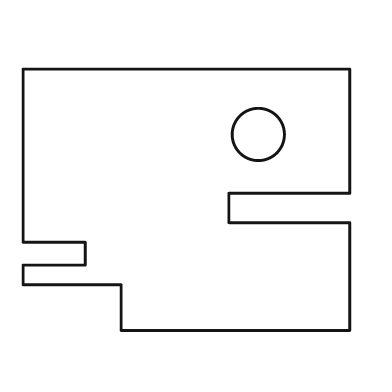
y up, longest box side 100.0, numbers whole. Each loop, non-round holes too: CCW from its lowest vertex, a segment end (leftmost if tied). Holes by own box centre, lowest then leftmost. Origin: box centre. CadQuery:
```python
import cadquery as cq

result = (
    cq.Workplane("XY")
    .moveTo(-20.0, -40.0)
    .lineTo(50.0, -40.0)
    .lineTo(50.0, -7.0)
    .lineTo(13.0, -7.0)
    .lineTo(13.0, 2.0)
    .lineTo(50.0, 2.0)
    .lineTo(50.0, 40.0)
    .lineTo(-50.0, 40.0)
    .lineTo(-50.0, -13.0)
    .lineTo(-31.0, -13.0)
    .lineTo(-31.0, -20.0)
    .lineTo(-50.0, -20.0)
    .lineTo(-50.0, -26.0)
    .lineTo(-20.0, -26.0)
    .close()
    .moveTo(22.0, 20.0)
    .circle(8.0)
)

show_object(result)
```